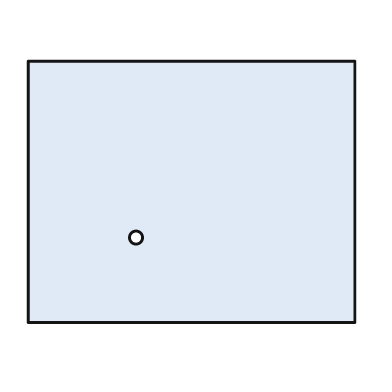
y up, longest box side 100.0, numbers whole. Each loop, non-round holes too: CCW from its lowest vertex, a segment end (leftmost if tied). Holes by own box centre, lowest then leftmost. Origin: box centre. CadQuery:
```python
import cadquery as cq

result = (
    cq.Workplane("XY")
    .moveTo(-50.0, -40.0)
    .lineTo(50.0, -40.0)
    .lineTo(50.0, 40.0)
    .lineTo(-50.0, 40.0)
    .close()
    .moveTo(-17.0, -14.0)
    .circle(2.0)
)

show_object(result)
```